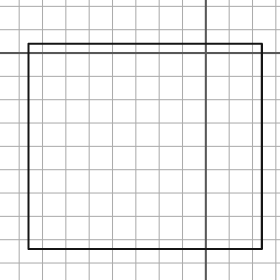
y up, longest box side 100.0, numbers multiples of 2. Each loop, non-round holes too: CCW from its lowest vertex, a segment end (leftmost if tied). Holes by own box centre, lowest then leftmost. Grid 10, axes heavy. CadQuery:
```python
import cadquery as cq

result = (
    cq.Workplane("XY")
    .moveTo(-76.0, -84.0)
    .lineTo(24.0, -84.0)
    .lineTo(24.0, 4.0)
    .lineTo(-76.0, 4.0)
    .close()
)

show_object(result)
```